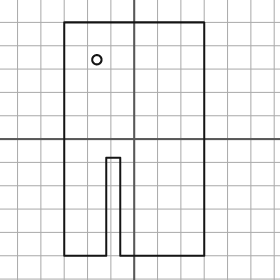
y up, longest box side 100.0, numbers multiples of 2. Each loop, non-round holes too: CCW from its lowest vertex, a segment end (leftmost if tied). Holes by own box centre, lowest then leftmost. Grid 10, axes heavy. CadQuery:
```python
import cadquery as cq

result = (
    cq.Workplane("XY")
    .moveTo(-30.0, -50.0)
    .lineTo(-12.0, -50.0)
    .lineTo(-12.0, -8.0)
    .lineTo(-6.0, -8.0)
    .lineTo(-6.0, -50.0)
    .lineTo(30.0, -50.0)
    .lineTo(30.0, 50.0)
    .lineTo(-30.0, 50.0)
    .close()
    .moveTo(-16.0, 34.0)
    .circle(2.0)
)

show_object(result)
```